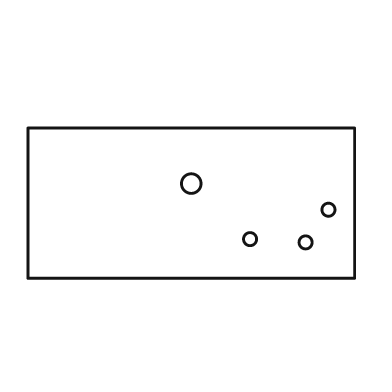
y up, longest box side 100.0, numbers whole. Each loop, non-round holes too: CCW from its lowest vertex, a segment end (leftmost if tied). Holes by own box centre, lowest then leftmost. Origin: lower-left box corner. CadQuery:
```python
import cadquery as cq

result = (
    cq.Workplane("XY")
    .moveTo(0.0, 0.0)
    .lineTo(100.0, 0.0)
    .lineTo(100.0, 46.0)
    .lineTo(0.0, 46.0)
    .close()
    .moveTo(85.0, 11.0)
    .circle(2.0)
    .moveTo(68.0, 12.0)
    .circle(2.0)
    .moveTo(92.0, 21.0)
    .circle(2.0)
    .moveTo(50.0, 29.0)
    .circle(3.0)
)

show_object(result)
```